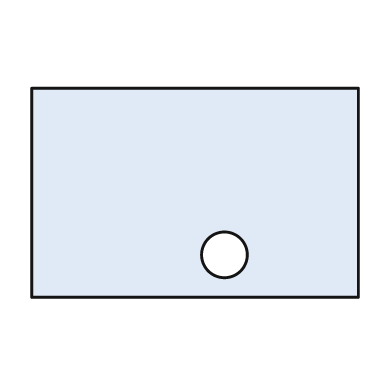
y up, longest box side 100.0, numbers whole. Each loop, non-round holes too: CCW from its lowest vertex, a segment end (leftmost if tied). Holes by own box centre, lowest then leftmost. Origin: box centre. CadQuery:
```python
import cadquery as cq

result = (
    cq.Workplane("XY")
    .moveTo(-50.0, -32.0)
    .lineTo(50.0, -32.0)
    .lineTo(50.0, 32.0)
    .lineTo(-50.0, 32.0)
    .close()
    .moveTo(9.0, -19.0)
    .circle(7.0)
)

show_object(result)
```